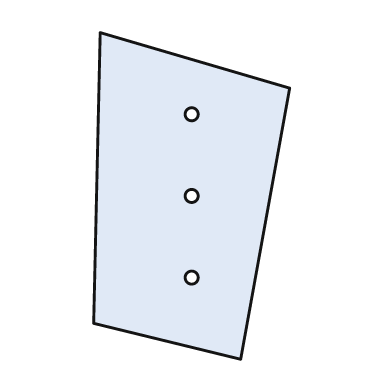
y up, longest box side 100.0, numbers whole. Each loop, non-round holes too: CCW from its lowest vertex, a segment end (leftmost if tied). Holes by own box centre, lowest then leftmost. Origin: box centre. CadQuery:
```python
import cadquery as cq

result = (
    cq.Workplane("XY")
    .moveTo(15.0, -50.0)
    .lineTo(30.0, 33.0)
    .lineTo(-28.0, 50.0)
    .lineTo(-30.0, -39.0)
    .close()
    .moveTo(0.0, -25.0)
    .circle(2.0)
    .moveTo(0.0, 0.0)
    .circle(2.0)
    .moveTo(0.0, 25.0)
    .circle(2.0)
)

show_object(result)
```